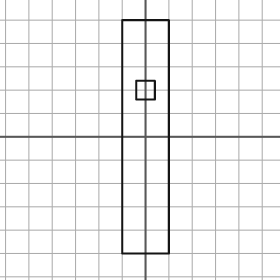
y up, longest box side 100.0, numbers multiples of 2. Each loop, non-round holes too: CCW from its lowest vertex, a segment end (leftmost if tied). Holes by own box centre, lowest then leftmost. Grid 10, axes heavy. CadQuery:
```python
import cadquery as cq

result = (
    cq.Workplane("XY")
    .moveTo(-10.0, -50.0)
    .lineTo(10.0, -50.0)
    .lineTo(10.0, 50.0)
    .lineTo(-10.0, 50.0)
    .close()
    .moveTo(-4.0, 16.0)
    .lineTo(4.0, 16.0)
    .lineTo(4.0, 24.0)
    .lineTo(-4.0, 24.0)
    .close()
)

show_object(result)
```